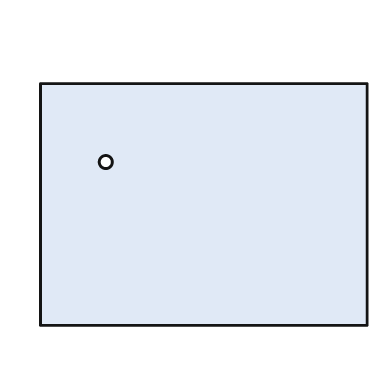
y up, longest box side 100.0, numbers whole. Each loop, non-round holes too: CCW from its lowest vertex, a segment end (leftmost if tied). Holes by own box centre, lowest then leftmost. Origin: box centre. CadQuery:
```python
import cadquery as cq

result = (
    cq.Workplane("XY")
    .moveTo(-50.0, -37.0)
    .lineTo(50.0, -37.0)
    .lineTo(50.0, 37.0)
    .lineTo(-50.0, 37.0)
    .close()
    .moveTo(-30.0, 13.0)
    .circle(2.0)
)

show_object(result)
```